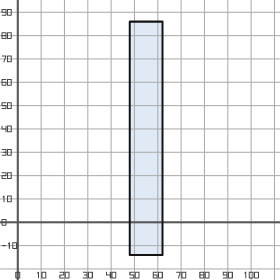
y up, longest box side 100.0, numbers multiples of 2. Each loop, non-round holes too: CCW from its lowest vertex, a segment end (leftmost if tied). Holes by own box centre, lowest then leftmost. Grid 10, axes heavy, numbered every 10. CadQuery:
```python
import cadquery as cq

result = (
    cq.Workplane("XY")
    .moveTo(48.0, -14.0)
    .lineTo(62.0, -14.0)
    .lineTo(62.0, 86.0)
    .lineTo(48.0, 86.0)
    .close()
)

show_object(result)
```